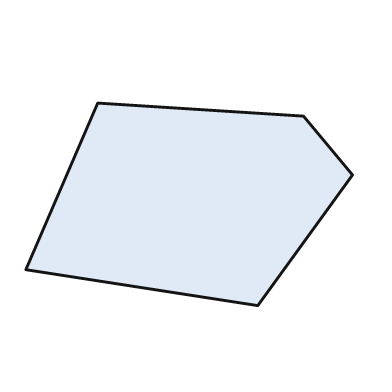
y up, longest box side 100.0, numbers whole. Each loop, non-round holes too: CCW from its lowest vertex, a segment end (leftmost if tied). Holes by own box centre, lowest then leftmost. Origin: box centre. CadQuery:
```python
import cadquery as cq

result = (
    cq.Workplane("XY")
    .moveTo(21.0, -31.0)
    .lineTo(50.0, 9.0)
    .lineTo(35.0, 27.0)
    .lineTo(-28.0, 31.0)
    .lineTo(-50.0, -20.0)
    .close()
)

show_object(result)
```